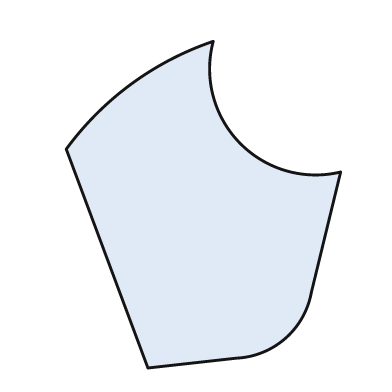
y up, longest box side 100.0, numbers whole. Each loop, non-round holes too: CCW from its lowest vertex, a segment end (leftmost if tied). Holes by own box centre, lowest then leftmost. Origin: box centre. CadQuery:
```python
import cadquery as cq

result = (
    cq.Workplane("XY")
    .moveTo(-17.0, -50.0)
    .lineTo(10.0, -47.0)
    .threePointArc((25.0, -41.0), (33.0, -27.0))
    .lineTo(42.0, 10.0)
    .threePointArc((11.0, 19.0), (3.0, 50.0))
    .threePointArc((-22.0, 37.0), (-42.0, 17.0))
    .close()
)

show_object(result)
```